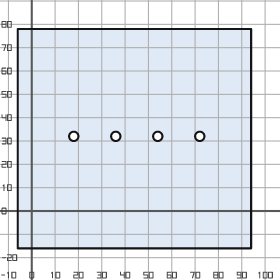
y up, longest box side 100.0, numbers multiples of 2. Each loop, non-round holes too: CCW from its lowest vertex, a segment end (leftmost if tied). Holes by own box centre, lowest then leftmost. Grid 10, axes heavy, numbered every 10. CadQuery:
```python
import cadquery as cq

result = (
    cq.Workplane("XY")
    .moveTo(-6.0, -16.0)
    .lineTo(94.0, -16.0)
    .lineTo(94.0, 78.0)
    .lineTo(-6.0, 78.0)
    .close()
    .moveTo(18.0, 32.0)
    .circle(2.0)
    .moveTo(36.0, 32.0)
    .circle(2.0)
    .moveTo(54.0, 32.0)
    .circle(2.0)
    .moveTo(72.0, 32.0)
    .circle(2.0)
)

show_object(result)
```